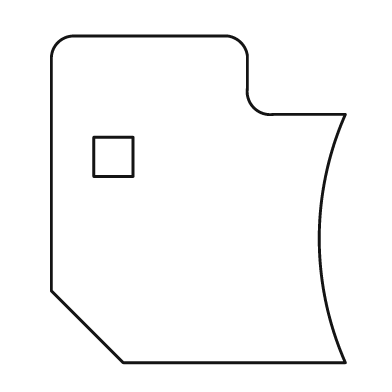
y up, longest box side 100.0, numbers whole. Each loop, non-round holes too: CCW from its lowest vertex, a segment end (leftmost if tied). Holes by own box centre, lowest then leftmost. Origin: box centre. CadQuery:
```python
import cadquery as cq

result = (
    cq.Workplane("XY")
    .moveTo(-23.0, -50.0)
    .lineTo(45.0, -50.0)
    .threePointArc((37.0, -12.0), (45.0, 26.0))
    .lineTo(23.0, 26.0)
    .threePointArc((17.0, 28.0), (15.0, 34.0))
    .lineTo(15.0, 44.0)
    .threePointArc((13.0, 48.0), (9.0, 50.0))
    .lineTo(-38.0, 50.0)
    .threePointArc((-43.0, 48.0), (-45.0, 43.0))
    .lineTo(-45.0, -28.0)
    .close()
    .moveTo(-32.0, 7.0)
    .lineTo(-20.0, 7.0)
    .lineTo(-20.0, 19.0)
    .lineTo(-32.0, 19.0)
    .close()
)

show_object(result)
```